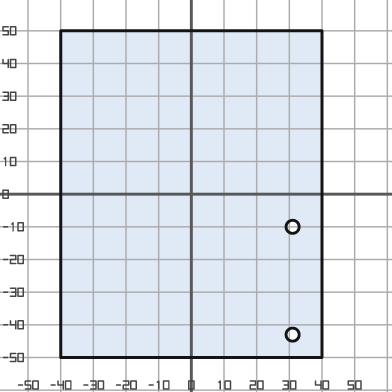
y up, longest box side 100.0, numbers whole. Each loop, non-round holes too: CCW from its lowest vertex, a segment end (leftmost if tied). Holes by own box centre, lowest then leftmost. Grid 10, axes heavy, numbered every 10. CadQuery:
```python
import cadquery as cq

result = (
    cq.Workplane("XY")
    .moveTo(-40.0, -50.0)
    .lineTo(40.0, -50.0)
    .lineTo(40.0, 50.0)
    .lineTo(-40.0, 50.0)
    .close()
    .moveTo(31.0, -43.0)
    .circle(2.0)
    .moveTo(31.0, -10.0)
    .circle(2.0)
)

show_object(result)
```